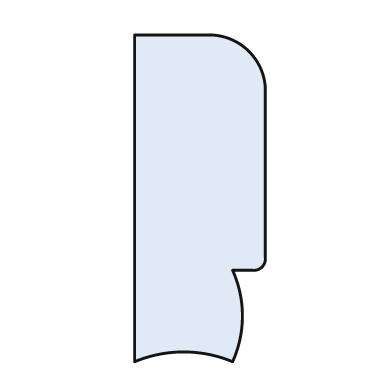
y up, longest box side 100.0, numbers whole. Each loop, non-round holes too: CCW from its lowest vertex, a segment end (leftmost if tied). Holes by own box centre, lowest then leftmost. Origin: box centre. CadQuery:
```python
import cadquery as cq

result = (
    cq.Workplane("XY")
    .moveTo(-20.0, -50.0)
    .threePointArc((-5.0, -47.0), (10.0, -50.0))
    .threePointArc((13.0, -36.0), (10.0, -22.0))
    .lineTo(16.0, -22.0)
    .threePointArc((19.0, -21.0), (20.0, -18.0))
    .lineTo(20.0, 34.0)
    .threePointArc((15.0, 45.0), (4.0, 50.0))
    .lineTo(-20.0, 50.0)
    .close()
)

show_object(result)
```